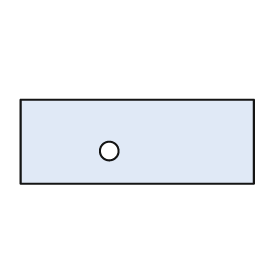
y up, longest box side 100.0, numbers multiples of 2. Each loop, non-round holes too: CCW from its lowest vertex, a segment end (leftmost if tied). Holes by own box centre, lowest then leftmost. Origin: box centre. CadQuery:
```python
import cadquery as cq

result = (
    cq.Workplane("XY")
    .moveTo(-50.0, -18.0)
    .lineTo(50.0, -18.0)
    .lineTo(50.0, 18.0)
    .lineTo(-50.0, 18.0)
    .close()
    .moveTo(-12.0, -4.0)
    .circle(4.0)
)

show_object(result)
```